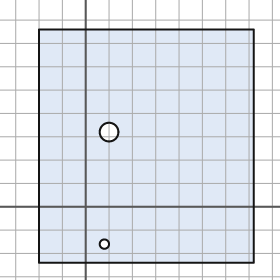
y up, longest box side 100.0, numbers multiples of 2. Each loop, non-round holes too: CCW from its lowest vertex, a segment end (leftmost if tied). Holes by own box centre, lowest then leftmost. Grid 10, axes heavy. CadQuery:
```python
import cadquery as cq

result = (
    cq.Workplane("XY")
    .moveTo(-20.0, -24.0)
    .lineTo(72.0, -24.0)
    .lineTo(72.0, 76.0)
    .lineTo(-20.0, 76.0)
    .close()
    .moveTo(8.0, -16.0)
    .circle(2.0)
    .moveTo(10.0, 32.0)
    .circle(4.0)
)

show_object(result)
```